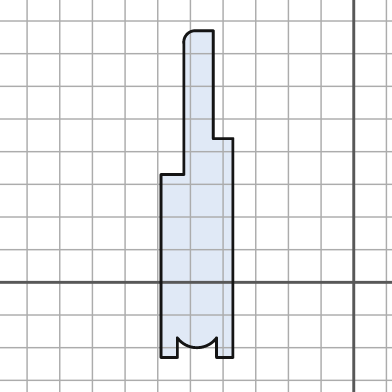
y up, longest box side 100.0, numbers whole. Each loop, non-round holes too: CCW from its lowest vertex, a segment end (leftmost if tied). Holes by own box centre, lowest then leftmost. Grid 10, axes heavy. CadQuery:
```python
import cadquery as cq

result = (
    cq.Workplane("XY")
    .moveTo(-59.0, -23.0)
    .lineTo(-54.0, -23.0)
    .lineTo(-54.0, -17.0)
    .threePointArc((-48.0, -20.0), (-42.0, -17.0))
    .lineTo(-42.0, -23.0)
    .lineTo(-37.0, -23.0)
    .lineTo(-37.0, 44.0)
    .lineTo(-43.0, 44.0)
    .lineTo(-43.0, 77.0)
    .lineTo(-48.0, 77.0)
    .threePointArc((-51.0, 76.0), (-52.0, 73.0))
    .lineTo(-52.0, 33.0)
    .lineTo(-59.0, 33.0)
    .close()
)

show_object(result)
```